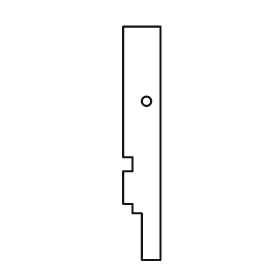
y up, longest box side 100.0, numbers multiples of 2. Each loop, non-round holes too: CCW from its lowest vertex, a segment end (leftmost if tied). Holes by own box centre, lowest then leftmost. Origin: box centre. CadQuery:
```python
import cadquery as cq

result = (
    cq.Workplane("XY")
    .moveTo(0.0, -50.0)
    .lineTo(8.0, -50.0)
    .lineTo(8.0, 50.0)
    .lineTo(-8.0, 50.0)
    .lineTo(-8.0, -6.0)
    .lineTo(-4.0, -6.0)
    .lineTo(-4.0, -12.0)
    .lineTo(-8.0, -12.0)
    .lineTo(-8.0, -26.0)
    .lineTo(-4.0, -26.0)
    .lineTo(-4.0, -30.0)
    .lineTo(0.0, -30.0)
    .close()
    .moveTo(2.0, 18.0)
    .circle(2.0)
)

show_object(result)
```